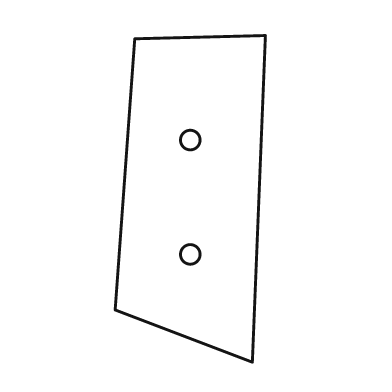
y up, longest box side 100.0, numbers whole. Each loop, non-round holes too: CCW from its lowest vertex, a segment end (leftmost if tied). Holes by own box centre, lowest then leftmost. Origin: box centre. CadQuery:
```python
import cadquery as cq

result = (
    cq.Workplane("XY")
    .moveTo(19.0, -50.0)
    .lineTo(23.0, 50.0)
    .lineTo(-17.0, 49.0)
    .lineTo(-23.0, -34.0)
    .close()
    .moveTo(0.0, -17.0)
    .circle(3.0)
    .moveTo(0.0, 18.0)
    .circle(3.0)
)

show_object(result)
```